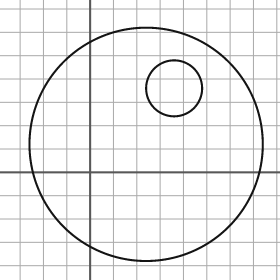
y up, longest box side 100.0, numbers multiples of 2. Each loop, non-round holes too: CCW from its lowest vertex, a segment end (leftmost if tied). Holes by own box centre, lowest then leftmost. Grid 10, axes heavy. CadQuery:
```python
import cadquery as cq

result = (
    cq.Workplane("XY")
    .moveTo(24.0, 12.0)
    .circle(50.0)
    .moveTo(36.0, 36.0)
    .circle(12.0)
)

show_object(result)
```